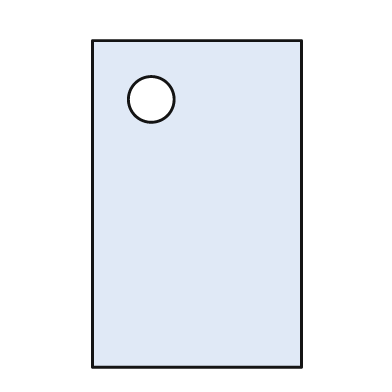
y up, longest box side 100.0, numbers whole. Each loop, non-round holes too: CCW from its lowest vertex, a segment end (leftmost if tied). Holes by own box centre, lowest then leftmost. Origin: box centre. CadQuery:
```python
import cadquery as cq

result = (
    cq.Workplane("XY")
    .moveTo(-32.0, -50.0)
    .lineTo(32.0, -50.0)
    .lineTo(32.0, 50.0)
    .lineTo(-32.0, 50.0)
    .close()
    .moveTo(-14.0, 32.0)
    .circle(7.0)
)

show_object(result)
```